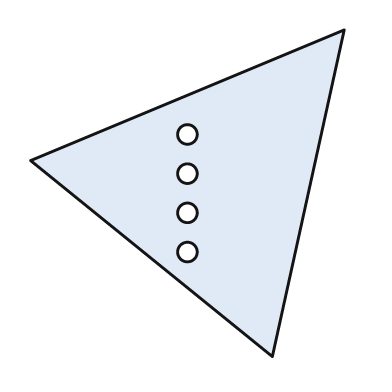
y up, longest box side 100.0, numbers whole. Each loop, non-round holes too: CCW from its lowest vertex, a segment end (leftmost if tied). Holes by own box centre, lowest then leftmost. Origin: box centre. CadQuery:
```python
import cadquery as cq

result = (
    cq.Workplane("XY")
    .moveTo(26.0, -50.0)
    .lineTo(48.0, 50.0)
    .lineTo(-48.0, 10.0)
    .close()
    .moveTo(0.0, -18.0)
    .circle(3.0)
    .moveTo(0.0, -6.0)
    .circle(3.0)
    .moveTo(0.0, 6.0)
    .circle(3.0)
    .moveTo(0.0, 18.0)
    .circle(3.0)
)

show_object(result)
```